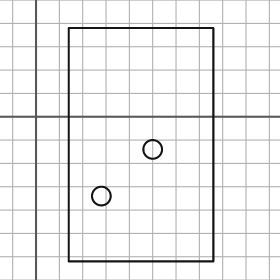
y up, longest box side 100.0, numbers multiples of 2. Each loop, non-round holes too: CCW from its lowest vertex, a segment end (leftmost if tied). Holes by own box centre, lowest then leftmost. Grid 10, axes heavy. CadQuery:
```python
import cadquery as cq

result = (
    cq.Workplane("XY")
    .moveTo(14.0, -62.0)
    .lineTo(76.0, -62.0)
    .lineTo(76.0, 38.0)
    .lineTo(14.0, 38.0)
    .close()
    .moveTo(28.0, -34.0)
    .circle(4.0)
    .moveTo(50.0, -14.0)
    .circle(4.0)
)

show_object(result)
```